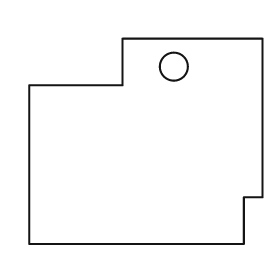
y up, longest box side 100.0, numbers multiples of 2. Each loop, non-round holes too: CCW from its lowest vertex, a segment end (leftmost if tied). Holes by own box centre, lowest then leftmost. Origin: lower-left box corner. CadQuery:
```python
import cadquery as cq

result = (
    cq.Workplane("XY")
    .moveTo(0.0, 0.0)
    .lineTo(92.0, 0.0)
    .lineTo(92.0, 20.0)
    .lineTo(100.0, 20.0)
    .lineTo(100.0, 88.0)
    .lineTo(40.0, 88.0)
    .lineTo(40.0, 68.0)
    .lineTo(0.0, 68.0)
    .close()
    .moveTo(62.0, 76.0)
    .circle(6.0)
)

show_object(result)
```